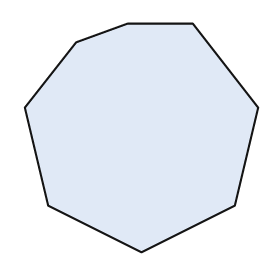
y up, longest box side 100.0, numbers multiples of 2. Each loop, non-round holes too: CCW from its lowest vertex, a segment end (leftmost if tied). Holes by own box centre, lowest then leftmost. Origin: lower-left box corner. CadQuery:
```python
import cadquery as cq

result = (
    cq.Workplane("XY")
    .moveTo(50.0, 0.0)
    .lineTo(90.0, 20.0)
    .lineTo(100.0, 62.0)
    .lineTo(72.0, 98.0)
    .lineTo(44.0, 98.0)
    .lineTo(22.0, 90.0)
    .lineTo(0.0, 62.0)
    .lineTo(10.0, 20.0)
    .close()
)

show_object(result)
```